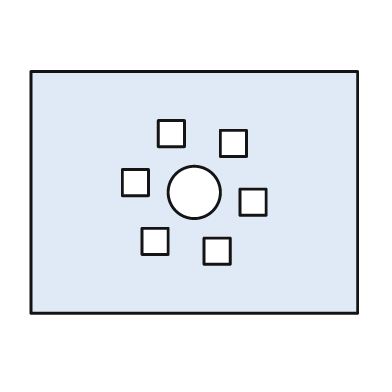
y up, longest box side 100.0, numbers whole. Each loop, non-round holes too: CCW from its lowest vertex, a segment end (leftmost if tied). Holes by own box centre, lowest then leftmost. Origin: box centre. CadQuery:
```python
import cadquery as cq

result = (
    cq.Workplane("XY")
    .moveTo(-50.0, -37.0)
    .lineTo(50.0, -37.0)
    .lineTo(50.0, 37.0)
    .lineTo(-50.0, 37.0)
    .close()
    .moveTo(3.0, -22.0)
    .lineTo(11.0, -22.0)
    .lineTo(11.0, -14.0)
    .lineTo(3.0, -14.0)
    .close()
    .moveTo(-16.0, -19.0)
    .lineTo(-8.0, -19.0)
    .lineTo(-8.0, -11.0)
    .lineTo(-16.0, -11.0)
    .close()
    .moveTo(14.0, -7.0)
    .lineTo(22.0, -7.0)
    .lineTo(22.0, 1.0)
    .lineTo(14.0, 1.0)
    .close()
    .moveTo(0.0, 0.0)
    .circle(8.0)
    .moveTo(-22.0, -1.0)
    .lineTo(-14.0, -1.0)
    .lineTo(-14.0, 7.0)
    .lineTo(-22.0, 7.0)
    .close()
    .moveTo(8.0, 11.0)
    .lineTo(16.0, 11.0)
    .lineTo(16.0, 19.0)
    .lineTo(8.0, 19.0)
    .close()
    .moveTo(-11.0, 14.0)
    .lineTo(-3.0, 14.0)
    .lineTo(-3.0, 22.0)
    .lineTo(-11.0, 22.0)
    .close()
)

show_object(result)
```